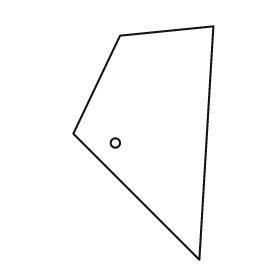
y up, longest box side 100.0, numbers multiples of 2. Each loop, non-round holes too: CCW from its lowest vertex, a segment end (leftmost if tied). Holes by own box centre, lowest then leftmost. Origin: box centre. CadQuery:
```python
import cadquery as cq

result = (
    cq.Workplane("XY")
    .moveTo(24.0, -50.0)
    .lineTo(30.0, 50.0)
    .lineTo(-10.0, 46.0)
    .lineTo(-30.0, 4.0)
    .close()
    .moveTo(-12.0, 0.0)
    .circle(2.0)
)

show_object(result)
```